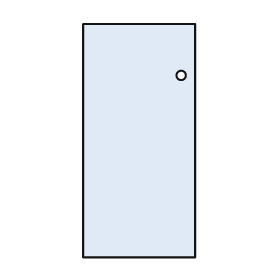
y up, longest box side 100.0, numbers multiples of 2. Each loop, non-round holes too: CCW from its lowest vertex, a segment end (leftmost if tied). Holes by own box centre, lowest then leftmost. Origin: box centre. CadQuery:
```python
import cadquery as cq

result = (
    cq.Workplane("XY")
    .moveTo(-24.0, -50.0)
    .lineTo(24.0, -50.0)
    .lineTo(24.0, 50.0)
    .lineTo(-24.0, 50.0)
    .close()
    .moveTo(18.0, 28.0)
    .circle(2.0)
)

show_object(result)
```